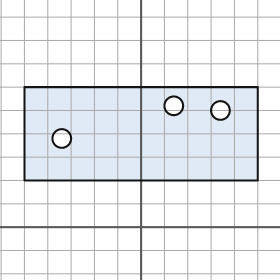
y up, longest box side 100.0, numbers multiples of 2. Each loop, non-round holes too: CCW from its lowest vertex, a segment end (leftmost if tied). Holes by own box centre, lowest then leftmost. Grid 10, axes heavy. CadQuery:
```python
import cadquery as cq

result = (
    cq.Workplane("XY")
    .moveTo(-50.0, 20.0)
    .lineTo(50.0, 20.0)
    .lineTo(50.0, 60.0)
    .lineTo(-50.0, 60.0)
    .close()
    .moveTo(-34.0, 38.0)
    .circle(4.0)
    .moveTo(34.0, 50.0)
    .circle(4.0)
    .moveTo(14.0, 52.0)
    .circle(4.0)
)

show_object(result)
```